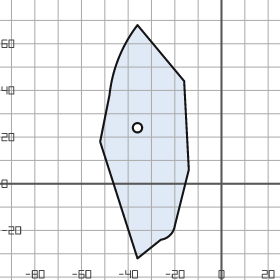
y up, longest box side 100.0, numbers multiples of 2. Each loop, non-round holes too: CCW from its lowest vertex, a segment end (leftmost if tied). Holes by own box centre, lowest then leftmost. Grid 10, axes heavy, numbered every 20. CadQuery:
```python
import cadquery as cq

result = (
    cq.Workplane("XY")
    .moveTo(-36.0, -32.0)
    .lineTo(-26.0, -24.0)
    .threePointArc((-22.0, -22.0), (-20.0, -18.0))
    .lineTo(-14.0, 6.0)
    .lineTo(-16.0, 44.0)
    .lineTo(-36.0, 68.0)
    .threePointArc((-44.0, 54.0), (-48.0, 38.0))
    .lineTo(-52.0, 18.0)
    .close()
    .moveTo(-36.0, 24.0)
    .circle(2.0)
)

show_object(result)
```